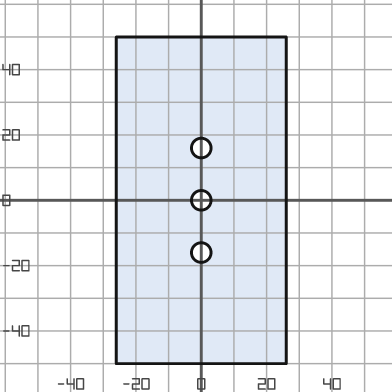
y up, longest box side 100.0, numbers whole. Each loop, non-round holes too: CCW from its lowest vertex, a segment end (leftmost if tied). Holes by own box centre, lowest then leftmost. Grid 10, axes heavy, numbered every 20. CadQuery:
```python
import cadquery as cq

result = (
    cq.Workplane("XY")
    .moveTo(-26.0, -50.0)
    .lineTo(26.0, -50.0)
    .lineTo(26.0, 50.0)
    .lineTo(-26.0, 50.0)
    .close()
    .moveTo(0.0, -16.0)
    .circle(3.0)
    .moveTo(0.0, 0.0)
    .circle(3.0)
    .moveTo(0.0, 16.0)
    .circle(3.0)
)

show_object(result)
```